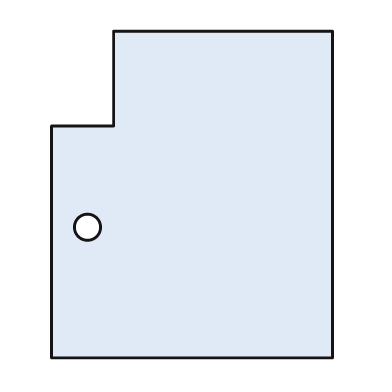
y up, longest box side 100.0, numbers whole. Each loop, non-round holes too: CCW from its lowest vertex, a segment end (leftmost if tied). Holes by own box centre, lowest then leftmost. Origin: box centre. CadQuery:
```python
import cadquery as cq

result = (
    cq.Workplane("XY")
    .moveTo(-43.0, -50.0)
    .lineTo(43.0, -50.0)
    .lineTo(43.0, 50.0)
    .lineTo(-24.0, 50.0)
    .lineTo(-24.0, 21.0)
    .lineTo(-43.0, 21.0)
    .close()
    .moveTo(-32.0, -10.0)
    .circle(4.0)
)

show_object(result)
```